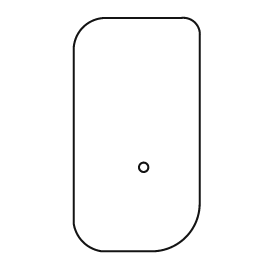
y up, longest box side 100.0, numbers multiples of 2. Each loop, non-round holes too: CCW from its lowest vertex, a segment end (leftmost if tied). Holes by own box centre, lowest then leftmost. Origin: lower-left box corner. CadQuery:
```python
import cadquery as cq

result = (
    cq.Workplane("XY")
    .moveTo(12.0, 0.0)
    .lineTo(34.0, 0.0)
    .threePointArc((48.0, 6.0), (54.0, 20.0))
    .lineTo(54.0, 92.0)
    .threePointArc((52.0, 98.0), (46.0, 100.0))
    .lineTo(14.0, 100.0)
    .threePointArc((4.0, 96.0), (0.0, 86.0))
    .lineTo(0.0, 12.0)
    .threePointArc((4.0, 4.0), (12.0, 0.0))
    .close()
    .moveTo(30.0, 36.0)
    .circle(2.0)
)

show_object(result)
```